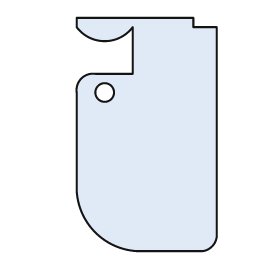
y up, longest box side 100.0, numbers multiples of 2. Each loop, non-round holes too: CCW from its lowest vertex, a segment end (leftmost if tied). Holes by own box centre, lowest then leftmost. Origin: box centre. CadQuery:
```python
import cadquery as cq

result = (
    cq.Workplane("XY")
    .moveTo(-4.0, -50.0)
    .lineTo(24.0, -50.0)
    .threePointArc((28.0, -48.0), (30.0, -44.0))
    .lineTo(30.0, 46.0)
    .lineTo(20.0, 46.0)
    .lineTo(20.0, 50.0)
    .lineTo(-30.0, 50.0)
    .lineTo(-30.0, 46.0)
    .threePointArc((-18.0, 40.0), (-6.0, 46.0))
    .lineTo(-6.0, 26.0)
    .lineTo(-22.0, 26.0)
    .threePointArc((-28.0, 24.0), (-30.0, 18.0))
    .lineTo(-30.0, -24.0)
    .threePointArc((-22.0, -42.0), (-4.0, -50.0))
    .close()
    .moveTo(-18.0, 18.0)
    .circle(4.0)
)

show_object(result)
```